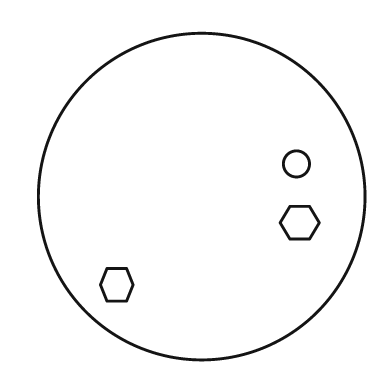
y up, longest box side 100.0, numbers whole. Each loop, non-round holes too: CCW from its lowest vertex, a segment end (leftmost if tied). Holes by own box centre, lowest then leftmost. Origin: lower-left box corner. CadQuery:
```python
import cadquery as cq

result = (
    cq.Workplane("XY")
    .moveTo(50.0, 50.0)
    .circle(50.0)
    .moveTo(21.0, 18.0)
    .lineTo(27.0, 18.0)
    .lineTo(29.0, 23.0)
    .lineTo(27.0, 28.0)
    .lineTo(21.0, 28.0)
    .lineTo(19.0, 23.0)
    .close()
    .moveTo(77.0, 37.0)
    .lineTo(83.0, 37.0)
    .lineTo(86.0, 42.0)
    .lineTo(83.0, 47.0)
    .lineTo(77.0, 47.0)
    .lineTo(74.0, 42.0)
    .close()
    .moveTo(79.0, 60.0)
    .circle(4.0)
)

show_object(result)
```